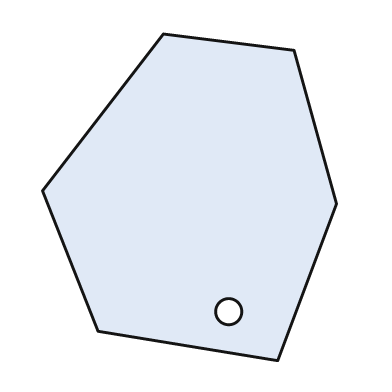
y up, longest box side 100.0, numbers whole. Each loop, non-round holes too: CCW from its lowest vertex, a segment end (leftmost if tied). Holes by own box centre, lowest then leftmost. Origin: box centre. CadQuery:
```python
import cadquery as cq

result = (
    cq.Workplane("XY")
    .moveTo(27.0, -50.0)
    .lineTo(45.0, -2.0)
    .lineTo(32.0, 45.0)
    .lineTo(-8.0, 50.0)
    .lineTo(-45.0, 2.0)
    .lineTo(-28.0, -41.0)
    .close()
    .moveTo(12.0, -35.0)
    .circle(4.0)
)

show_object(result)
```